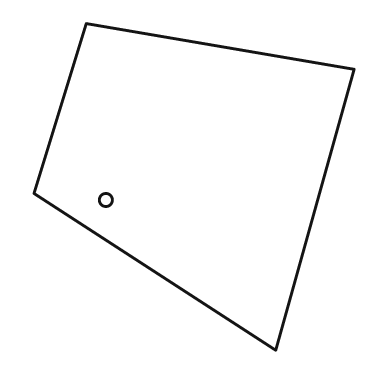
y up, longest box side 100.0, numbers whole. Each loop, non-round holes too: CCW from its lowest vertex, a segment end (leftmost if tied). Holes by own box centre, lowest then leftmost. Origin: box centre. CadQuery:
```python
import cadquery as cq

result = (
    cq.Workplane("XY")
    .moveTo(25.0, -50.0)
    .lineTo(49.0, 36.0)
    .lineTo(-33.0, 50.0)
    .lineTo(-49.0, -2.0)
    .close()
    .moveTo(-27.0, -4.0)
    .circle(2.0)
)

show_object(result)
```